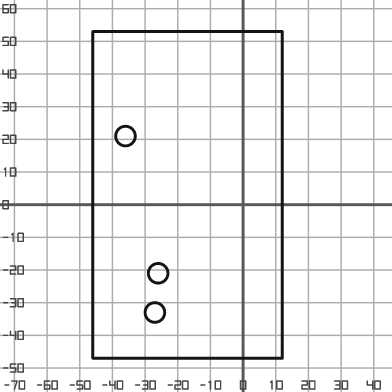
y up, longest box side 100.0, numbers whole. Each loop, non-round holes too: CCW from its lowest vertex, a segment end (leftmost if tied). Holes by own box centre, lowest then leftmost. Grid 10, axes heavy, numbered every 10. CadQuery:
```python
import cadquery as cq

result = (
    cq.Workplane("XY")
    .moveTo(-46.0, -47.0)
    .lineTo(12.0, -47.0)
    .lineTo(12.0, 53.0)
    .lineTo(-46.0, 53.0)
    .close()
    .moveTo(-27.0, -33.0)
    .circle(3.0)
    .moveTo(-26.0, -21.0)
    .circle(3.0)
    .moveTo(-36.0, 21.0)
    .circle(3.0)
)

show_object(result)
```